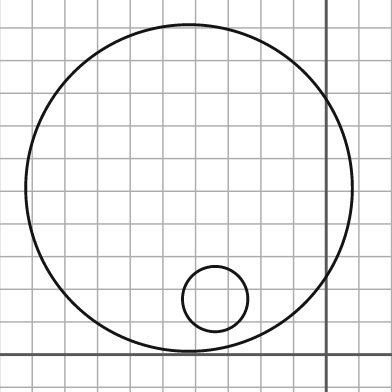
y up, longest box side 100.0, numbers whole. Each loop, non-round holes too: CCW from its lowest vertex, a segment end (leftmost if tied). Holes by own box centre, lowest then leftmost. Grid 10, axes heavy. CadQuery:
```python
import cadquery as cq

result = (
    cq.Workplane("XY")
    .moveTo(-42.0, 51.0)
    .circle(50.0)
    .moveTo(-34.0, 17.0)
    .circle(10.0)
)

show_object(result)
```